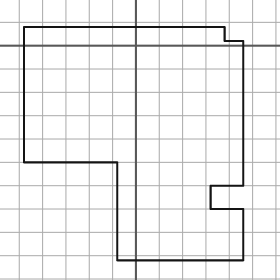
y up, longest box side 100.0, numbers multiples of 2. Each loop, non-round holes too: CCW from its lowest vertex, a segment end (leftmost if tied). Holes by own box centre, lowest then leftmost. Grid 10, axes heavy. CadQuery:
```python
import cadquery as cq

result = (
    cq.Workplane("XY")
    .moveTo(-8.0, -92.0)
    .lineTo(46.0, -92.0)
    .lineTo(46.0, -70.0)
    .lineTo(32.0, -70.0)
    .lineTo(32.0, -60.0)
    .lineTo(46.0, -60.0)
    .lineTo(46.0, 2.0)
    .lineTo(38.0, 2.0)
    .lineTo(38.0, 8.0)
    .lineTo(-48.0, 8.0)
    .lineTo(-48.0, -50.0)
    .lineTo(-8.0, -50.0)
    .close()
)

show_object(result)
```